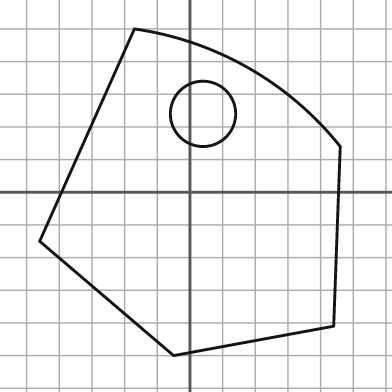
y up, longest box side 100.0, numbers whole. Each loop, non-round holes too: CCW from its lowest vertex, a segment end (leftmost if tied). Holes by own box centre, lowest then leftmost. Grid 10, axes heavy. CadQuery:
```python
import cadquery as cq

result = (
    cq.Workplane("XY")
    .moveTo(-5.0, -50.0)
    .lineTo(44.0, -41.0)
    .lineTo(46.0, 14.0)
    .threePointArc((18.0, 38.0), (-17.0, 50.0))
    .lineTo(-46.0, -15.0)
    .close()
    .moveTo(4.0, 24.0)
    .circle(10.0)
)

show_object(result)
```